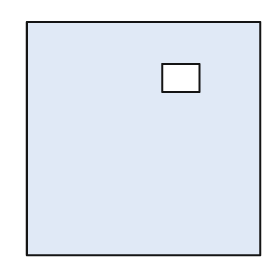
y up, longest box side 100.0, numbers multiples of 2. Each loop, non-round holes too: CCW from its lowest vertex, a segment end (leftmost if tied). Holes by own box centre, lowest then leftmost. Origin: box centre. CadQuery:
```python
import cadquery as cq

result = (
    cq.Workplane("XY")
    .moveTo(-50.0, -50.0)
    .lineTo(50.0, -50.0)
    .lineTo(50.0, 50.0)
    .lineTo(-50.0, 50.0)
    .close()
    .moveTo(8.0, 20.0)
    .lineTo(24.0, 20.0)
    .lineTo(24.0, 32.0)
    .lineTo(8.0, 32.0)
    .close()
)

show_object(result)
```